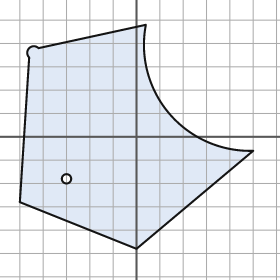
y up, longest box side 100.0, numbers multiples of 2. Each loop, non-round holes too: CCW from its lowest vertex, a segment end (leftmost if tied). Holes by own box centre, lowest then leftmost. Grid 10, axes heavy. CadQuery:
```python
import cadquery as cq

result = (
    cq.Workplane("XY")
    .moveTo(0.0, -48.0)
    .lineTo(50.0, -6.0)
    .threePointArc((14.0, 10.0), (4.0, 48.0))
    .lineTo(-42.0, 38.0)
    .threePointArc((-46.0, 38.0), (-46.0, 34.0))
    .lineTo(-50.0, -28.0)
    .close()
    .moveTo(-30.0, -18.0)
    .circle(2.0)
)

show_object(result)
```